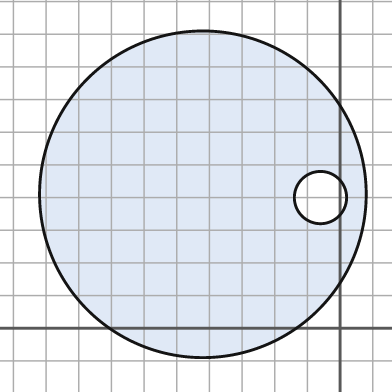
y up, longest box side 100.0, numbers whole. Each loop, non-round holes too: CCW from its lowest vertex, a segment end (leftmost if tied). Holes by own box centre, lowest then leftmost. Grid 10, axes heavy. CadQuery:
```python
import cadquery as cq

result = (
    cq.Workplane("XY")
    .moveTo(-42.0, 41.0)
    .circle(50.0)
    .moveTo(-6.0, 40.0)
    .circle(8.0)
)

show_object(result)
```